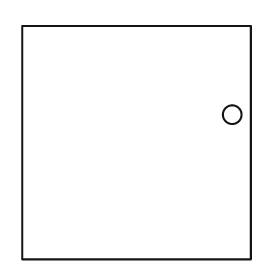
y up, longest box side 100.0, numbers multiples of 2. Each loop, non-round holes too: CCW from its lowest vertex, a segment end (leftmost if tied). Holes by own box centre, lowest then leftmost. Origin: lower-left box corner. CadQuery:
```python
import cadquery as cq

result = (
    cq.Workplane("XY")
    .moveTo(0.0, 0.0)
    .lineTo(98.0, 0.0)
    .lineTo(98.0, 100.0)
    .lineTo(0.0, 100.0)
    .close()
    .moveTo(90.0, 62.0)
    .circle(4.0)
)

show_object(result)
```